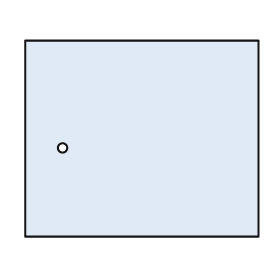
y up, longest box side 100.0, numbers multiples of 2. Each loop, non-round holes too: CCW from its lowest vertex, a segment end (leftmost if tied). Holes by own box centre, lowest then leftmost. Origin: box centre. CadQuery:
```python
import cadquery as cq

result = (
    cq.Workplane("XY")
    .moveTo(-50.0, -42.0)
    .lineTo(50.0, -42.0)
    .lineTo(50.0, 42.0)
    .lineTo(-50.0, 42.0)
    .close()
    .moveTo(-34.0, -4.0)
    .circle(2.0)
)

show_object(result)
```